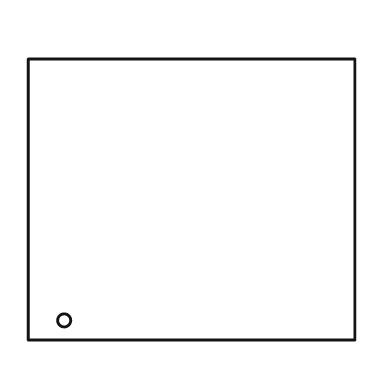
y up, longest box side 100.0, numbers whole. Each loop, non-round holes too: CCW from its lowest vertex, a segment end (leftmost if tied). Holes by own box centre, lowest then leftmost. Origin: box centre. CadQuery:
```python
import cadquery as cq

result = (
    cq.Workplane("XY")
    .moveTo(-50.0, -43.0)
    .lineTo(50.0, -43.0)
    .lineTo(50.0, 43.0)
    .lineTo(-50.0, 43.0)
    .close()
    .moveTo(-39.0, -37.0)
    .circle(2.0)
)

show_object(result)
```